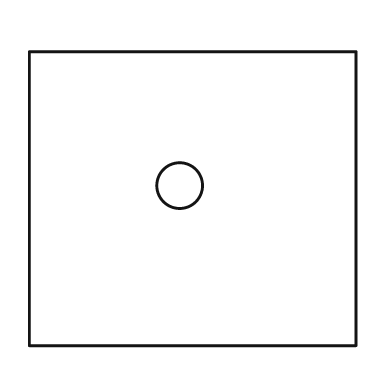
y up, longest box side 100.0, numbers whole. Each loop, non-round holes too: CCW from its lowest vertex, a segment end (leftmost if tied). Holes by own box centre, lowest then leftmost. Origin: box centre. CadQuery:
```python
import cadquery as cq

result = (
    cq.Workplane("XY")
    .moveTo(-50.0, -45.0)
    .lineTo(50.0, -45.0)
    .lineTo(50.0, 45.0)
    .lineTo(-50.0, 45.0)
    .close()
    .moveTo(-4.0, 4.0)
    .circle(7.0)
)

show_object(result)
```